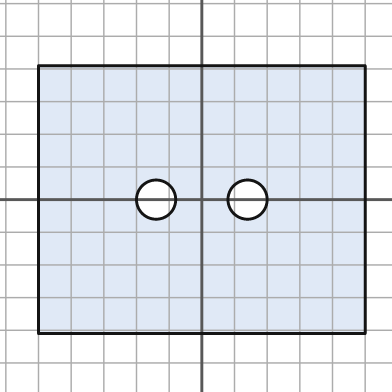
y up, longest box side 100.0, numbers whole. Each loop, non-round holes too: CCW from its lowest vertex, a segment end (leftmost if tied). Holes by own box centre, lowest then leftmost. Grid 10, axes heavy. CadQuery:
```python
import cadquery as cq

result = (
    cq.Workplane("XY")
    .moveTo(-50.0, -41.0)
    .lineTo(50.0, -41.0)
    .lineTo(50.0, 41.0)
    .lineTo(-50.0, 41.0)
    .close()
    .moveTo(-14.0, 0.0)
    .circle(6.0)
    .moveTo(14.0, 0.0)
    .circle(6.0)
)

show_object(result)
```